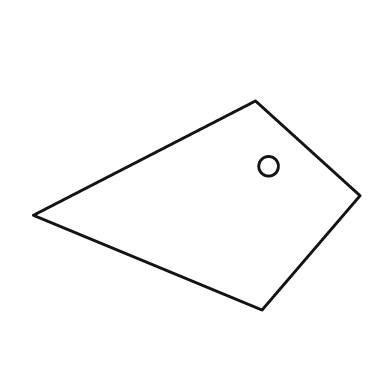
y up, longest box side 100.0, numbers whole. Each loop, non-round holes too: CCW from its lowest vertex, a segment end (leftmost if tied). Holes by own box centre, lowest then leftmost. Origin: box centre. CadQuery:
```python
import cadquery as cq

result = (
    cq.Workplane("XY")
    .moveTo(20.0, -32.0)
    .lineTo(50.0, 3.0)
    .lineTo(18.0, 32.0)
    .lineTo(-50.0, -3.0)
    .close()
    .moveTo(22.0, 12.0)
    .circle(3.0)
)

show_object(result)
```